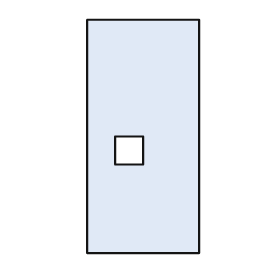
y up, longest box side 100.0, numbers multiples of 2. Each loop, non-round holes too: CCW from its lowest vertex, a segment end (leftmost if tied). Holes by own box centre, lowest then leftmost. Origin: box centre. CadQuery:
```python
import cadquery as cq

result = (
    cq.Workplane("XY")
    .moveTo(-24.0, -50.0)
    .lineTo(24.0, -50.0)
    .lineTo(24.0, 50.0)
    .lineTo(-24.0, 50.0)
    .close()
    .moveTo(-12.0, -12.0)
    .lineTo(0.0, -12.0)
    .lineTo(0.0, 0.0)
    .lineTo(-12.0, 0.0)
    .close()
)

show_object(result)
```